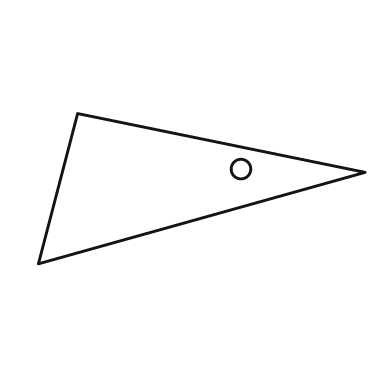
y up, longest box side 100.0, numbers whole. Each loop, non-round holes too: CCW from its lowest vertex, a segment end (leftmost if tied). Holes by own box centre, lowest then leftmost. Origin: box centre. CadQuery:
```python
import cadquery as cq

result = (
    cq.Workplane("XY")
    .moveTo(-50.0, -23.0)
    .lineTo(50.0, 5.0)
    .lineTo(-38.0, 23.0)
    .close()
    .moveTo(12.0, 6.0)
    .circle(3.0)
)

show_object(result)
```